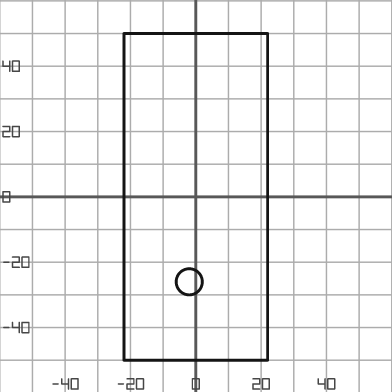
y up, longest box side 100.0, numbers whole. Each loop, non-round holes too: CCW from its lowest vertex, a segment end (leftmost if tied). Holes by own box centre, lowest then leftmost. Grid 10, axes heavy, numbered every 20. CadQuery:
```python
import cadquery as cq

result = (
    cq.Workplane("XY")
    .moveTo(-22.0, -50.0)
    .lineTo(22.0, -50.0)
    .lineTo(22.0, 50.0)
    .lineTo(-22.0, 50.0)
    .close()
    .moveTo(-2.0, -26.0)
    .circle(4.0)
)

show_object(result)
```